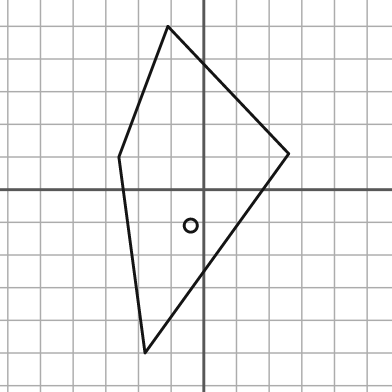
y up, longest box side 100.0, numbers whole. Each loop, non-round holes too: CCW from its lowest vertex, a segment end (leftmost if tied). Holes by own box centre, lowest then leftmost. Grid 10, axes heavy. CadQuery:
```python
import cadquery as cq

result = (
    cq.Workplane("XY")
    .moveTo(-18.0, -50.0)
    .lineTo(26.0, 11.0)
    .lineTo(-11.0, 50.0)
    .lineTo(-26.0, 10.0)
    .close()
    .moveTo(-4.0, -11.0)
    .circle(2.0)
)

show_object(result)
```